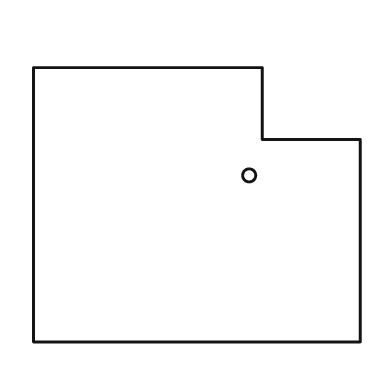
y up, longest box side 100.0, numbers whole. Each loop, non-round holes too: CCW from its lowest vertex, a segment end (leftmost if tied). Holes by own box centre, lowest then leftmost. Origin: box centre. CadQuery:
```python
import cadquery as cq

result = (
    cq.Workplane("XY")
    .moveTo(-50.0, -42.0)
    .lineTo(50.0, -42.0)
    .lineTo(50.0, 20.0)
    .lineTo(20.0, 20.0)
    .lineTo(20.0, 42.0)
    .lineTo(-50.0, 42.0)
    .close()
    .moveTo(16.0, 9.0)
    .circle(2.0)
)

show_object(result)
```